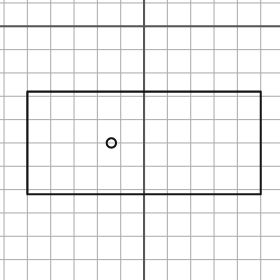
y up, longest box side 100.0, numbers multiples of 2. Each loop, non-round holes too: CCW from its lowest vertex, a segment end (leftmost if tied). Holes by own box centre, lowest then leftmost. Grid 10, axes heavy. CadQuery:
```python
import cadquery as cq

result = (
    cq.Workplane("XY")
    .moveTo(-50.0, -72.0)
    .lineTo(50.0, -72.0)
    .lineTo(50.0, -28.0)
    .lineTo(-50.0, -28.0)
    .close()
    .moveTo(-14.0, -50.0)
    .circle(2.0)
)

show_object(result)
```